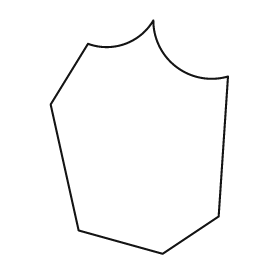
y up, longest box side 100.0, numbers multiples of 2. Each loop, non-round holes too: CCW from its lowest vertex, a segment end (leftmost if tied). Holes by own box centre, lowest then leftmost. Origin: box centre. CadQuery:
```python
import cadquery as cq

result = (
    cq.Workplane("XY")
    .moveTo(10.0, -50.0)
    .lineTo(34.0, -34.0)
    .lineTo(38.0, 26.0)
    .threePointArc((16.0, 30.0), (6.0, 50.0))
    .threePointArc((-6.0, 40.0), (-22.0, 40.0))
    .lineTo(-38.0, 14.0)
    .lineTo(-26.0, -40.0)
    .close()
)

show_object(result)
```